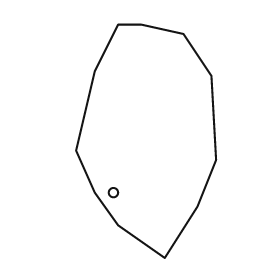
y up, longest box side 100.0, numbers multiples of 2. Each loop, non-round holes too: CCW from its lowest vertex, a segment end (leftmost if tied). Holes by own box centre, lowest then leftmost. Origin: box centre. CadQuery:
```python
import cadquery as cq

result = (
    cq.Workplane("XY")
    .moveTo(8.0, -50.0)
    .lineTo(22.0, -28.0)
    .lineTo(30.0, -8.0)
    .lineTo(28.0, 28.0)
    .lineTo(16.0, 46.0)
    .lineTo(-2.0, 50.0)
    .lineTo(-12.0, 50.0)
    .lineTo(-22.0, 30.0)
    .lineTo(-30.0, -4.0)
    .lineTo(-22.0, -22.0)
    .lineTo(-12.0, -36.0)
    .close()
    .moveTo(-14.0, -22.0)
    .circle(2.0)
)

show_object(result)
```